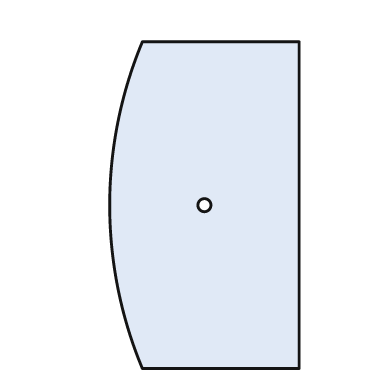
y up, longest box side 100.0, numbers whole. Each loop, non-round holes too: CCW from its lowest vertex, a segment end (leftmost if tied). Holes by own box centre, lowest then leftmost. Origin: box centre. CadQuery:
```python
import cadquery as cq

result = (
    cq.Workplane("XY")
    .moveTo(-19.0, -50.0)
    .lineTo(29.0, -50.0)
    .lineTo(29.0, 50.0)
    .lineTo(-19.0, 50.0)
    .threePointArc((-29.0, 0.0), (-19.0, -50.0))
    .close()
    .moveTo(0.0, 0.0)
    .circle(2.0)
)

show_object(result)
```